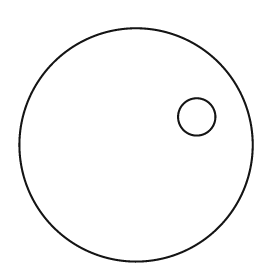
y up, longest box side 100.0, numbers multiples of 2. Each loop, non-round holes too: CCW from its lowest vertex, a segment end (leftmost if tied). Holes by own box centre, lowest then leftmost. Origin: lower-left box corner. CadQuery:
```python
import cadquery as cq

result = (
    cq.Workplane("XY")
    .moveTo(50.0, 50.0)
    .circle(50.0)
    .moveTo(76.0, 62.0)
    .circle(8.0)
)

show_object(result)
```